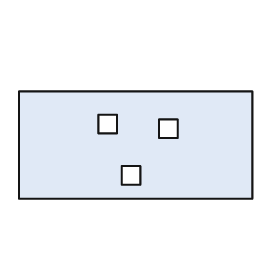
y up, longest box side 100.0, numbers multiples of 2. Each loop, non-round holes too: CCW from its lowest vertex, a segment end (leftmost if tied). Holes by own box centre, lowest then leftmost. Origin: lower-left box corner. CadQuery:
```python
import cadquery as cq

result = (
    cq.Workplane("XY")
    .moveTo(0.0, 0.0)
    .lineTo(100.0, 0.0)
    .lineTo(100.0, 46.0)
    .lineTo(0.0, 46.0)
    .close()
    .moveTo(44.0, 6.0)
    .lineTo(52.0, 6.0)
    .lineTo(52.0, 14.0)
    .lineTo(44.0, 14.0)
    .close()
    .moveTo(60.0, 26.0)
    .lineTo(68.0, 26.0)
    .lineTo(68.0, 34.0)
    .lineTo(60.0, 34.0)
    .close()
    .moveTo(34.0, 28.0)
    .lineTo(42.0, 28.0)
    .lineTo(42.0, 36.0)
    .lineTo(34.0, 36.0)
    .close()
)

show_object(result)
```